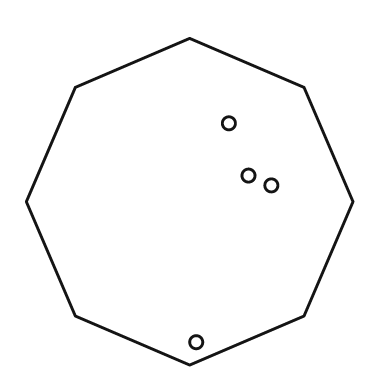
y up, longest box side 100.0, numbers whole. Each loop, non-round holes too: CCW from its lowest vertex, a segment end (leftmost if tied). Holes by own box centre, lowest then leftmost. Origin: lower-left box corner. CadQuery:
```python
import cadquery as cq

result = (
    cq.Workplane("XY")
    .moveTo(50.0, 0.0)
    .lineTo(85.0, 15.0)
    .lineTo(100.0, 50.0)
    .lineTo(85.0, 85.0)
    .lineTo(50.0, 100.0)
    .lineTo(15.0, 85.0)
    .lineTo(0.0, 50.0)
    .lineTo(15.0, 15.0)
    .close()
    .moveTo(52.0, 7.0)
    .circle(2.0)
    .moveTo(75.0, 55.0)
    .circle(2.0)
    .moveTo(68.0, 58.0)
    .circle(2.0)
    .moveTo(62.0, 74.0)
    .circle(2.0)
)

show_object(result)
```